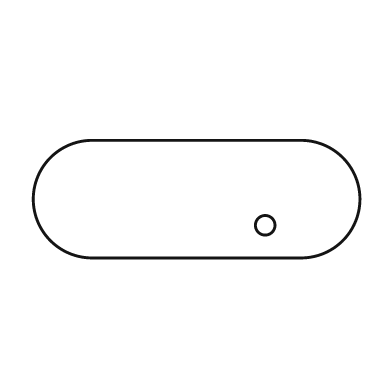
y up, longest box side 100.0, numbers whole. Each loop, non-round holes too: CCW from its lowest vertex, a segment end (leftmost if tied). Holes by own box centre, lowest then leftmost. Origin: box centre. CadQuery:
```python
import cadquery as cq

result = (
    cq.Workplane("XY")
    .moveTo(-32.0, -18.0)
    .lineTo(32.0, -18.0)
    .threePointArc((50.0, 0.0), (32.0, 18.0))
    .lineTo(-32.0, 18.0)
    .threePointArc((-50.0, 0.0), (-32.0, -18.0))
    .close()
    .moveTo(21.0, -8.0)
    .circle(3.0)
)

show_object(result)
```